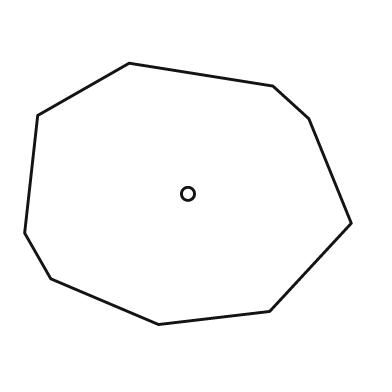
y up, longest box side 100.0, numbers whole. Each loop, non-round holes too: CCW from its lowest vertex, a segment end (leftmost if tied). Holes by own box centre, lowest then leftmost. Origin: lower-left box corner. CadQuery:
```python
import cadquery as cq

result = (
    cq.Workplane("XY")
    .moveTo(41.0, 0.0)
    .lineTo(75.0, 4.0)
    .lineTo(100.0, 31.0)
    .lineTo(87.0, 63.0)
    .lineTo(76.0, 73.0)
    .lineTo(32.0, 80.0)
    .lineTo(4.0, 64.0)
    .lineTo(0.0, 28.0)
    .lineTo(8.0, 14.0)
    .close()
    .moveTo(50.0, 40.0)
    .circle(2.0)
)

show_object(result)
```